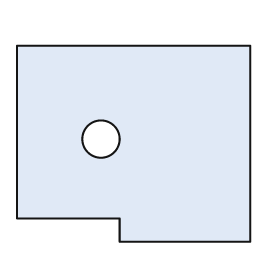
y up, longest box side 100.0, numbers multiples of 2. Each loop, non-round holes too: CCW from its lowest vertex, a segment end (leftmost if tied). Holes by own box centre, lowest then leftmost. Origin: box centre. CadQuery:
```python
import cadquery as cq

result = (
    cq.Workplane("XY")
    .moveTo(-6.0, -42.0)
    .lineTo(50.0, -42.0)
    .lineTo(50.0, 42.0)
    .lineTo(-50.0, 42.0)
    .lineTo(-50.0, -32.0)
    .lineTo(-6.0, -32.0)
    .close()
    .moveTo(-14.0, 2.0)
    .circle(8.0)
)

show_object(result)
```